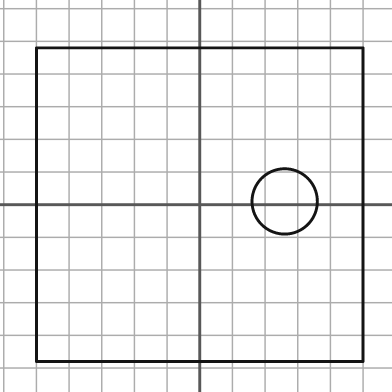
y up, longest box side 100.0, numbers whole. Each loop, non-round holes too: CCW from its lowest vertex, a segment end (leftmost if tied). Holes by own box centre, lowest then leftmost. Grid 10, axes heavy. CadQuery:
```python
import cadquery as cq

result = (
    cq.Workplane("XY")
    .moveTo(-50.0, -48.0)
    .lineTo(50.0, -48.0)
    .lineTo(50.0, 48.0)
    .lineTo(-50.0, 48.0)
    .close()
    .moveTo(26.0, 1.0)
    .circle(10.0)
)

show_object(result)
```